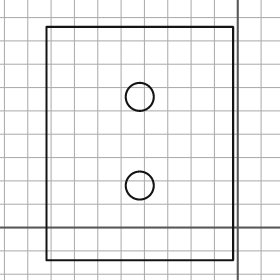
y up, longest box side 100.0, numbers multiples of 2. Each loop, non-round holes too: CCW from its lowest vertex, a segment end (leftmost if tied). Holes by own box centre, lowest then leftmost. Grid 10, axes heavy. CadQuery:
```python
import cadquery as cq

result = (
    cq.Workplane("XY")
    .moveTo(-82.0, -14.0)
    .lineTo(-2.0, -14.0)
    .lineTo(-2.0, 86.0)
    .lineTo(-82.0, 86.0)
    .close()
    .moveTo(-42.0, 18.0)
    .circle(6.0)
    .moveTo(-42.0, 56.0)
    .circle(6.0)
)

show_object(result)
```